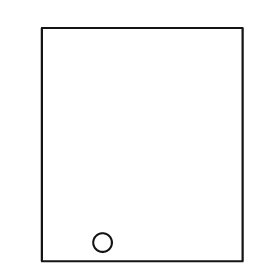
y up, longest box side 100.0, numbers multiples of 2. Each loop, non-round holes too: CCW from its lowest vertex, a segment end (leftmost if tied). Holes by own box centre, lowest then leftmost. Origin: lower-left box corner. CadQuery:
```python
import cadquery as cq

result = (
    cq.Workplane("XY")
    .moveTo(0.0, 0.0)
    .lineTo(86.0, 0.0)
    .lineTo(86.0, 100.0)
    .lineTo(0.0, 100.0)
    .close()
    .moveTo(26.0, 8.0)
    .circle(4.0)
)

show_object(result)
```